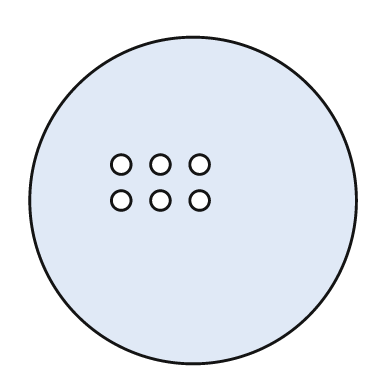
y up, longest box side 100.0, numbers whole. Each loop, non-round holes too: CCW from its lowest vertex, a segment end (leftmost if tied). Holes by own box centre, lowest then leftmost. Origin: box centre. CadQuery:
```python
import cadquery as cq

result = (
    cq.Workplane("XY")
    .moveTo(0.0, 0.0)
    .circle(50.0)
    .moveTo(-22.0, 0.0)
    .circle(3.0)
    .moveTo(-10.0, 0.0)
    .circle(3.0)
    .moveTo(2.0, 0.0)
    .circle(3.0)
    .moveTo(-22.0, 11.0)
    .circle(3.0)
    .moveTo(-10.0, 11.0)
    .circle(3.0)
    .moveTo(2.0, 11.0)
    .circle(3.0)
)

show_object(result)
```